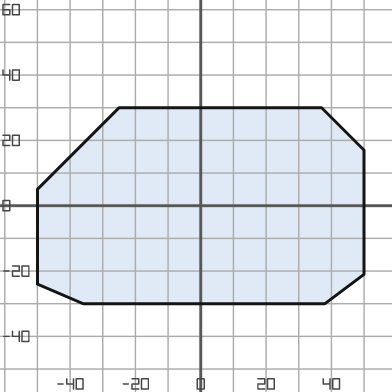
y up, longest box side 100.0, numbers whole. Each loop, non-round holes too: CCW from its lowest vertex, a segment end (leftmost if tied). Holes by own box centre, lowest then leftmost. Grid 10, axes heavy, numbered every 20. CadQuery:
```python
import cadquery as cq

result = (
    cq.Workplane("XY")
    .moveTo(-36.0, -30.0)
    .lineTo(38.0, -30.0)
    .lineTo(50.0, -21.0)
    .lineTo(50.0, 17.0)
    .lineTo(37.0, 30.0)
    .lineTo(-25.0, 30.0)
    .lineTo(-50.0, 5.0)
    .lineTo(-50.0, -24.0)
    .close()
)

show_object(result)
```